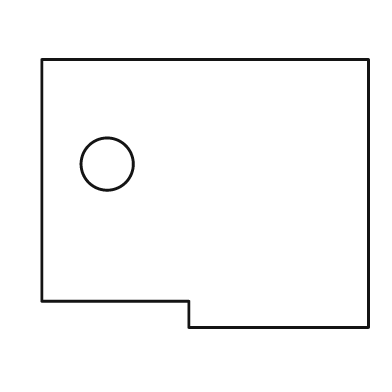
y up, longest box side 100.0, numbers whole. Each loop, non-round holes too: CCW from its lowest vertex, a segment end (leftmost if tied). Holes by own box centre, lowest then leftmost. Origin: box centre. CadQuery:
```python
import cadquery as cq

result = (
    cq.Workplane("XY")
    .moveTo(-5.0, -41.0)
    .lineTo(50.0, -41.0)
    .lineTo(50.0, 41.0)
    .lineTo(-50.0, 41.0)
    .lineTo(-50.0, -33.0)
    .lineTo(-5.0, -33.0)
    .close()
    .moveTo(-30.0, 9.0)
    .circle(8.0)
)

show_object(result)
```